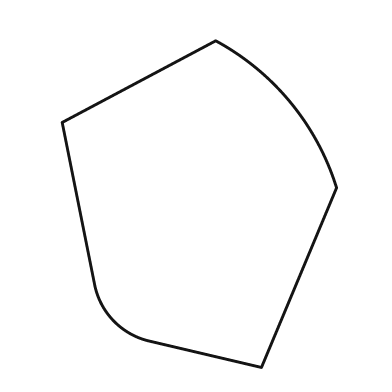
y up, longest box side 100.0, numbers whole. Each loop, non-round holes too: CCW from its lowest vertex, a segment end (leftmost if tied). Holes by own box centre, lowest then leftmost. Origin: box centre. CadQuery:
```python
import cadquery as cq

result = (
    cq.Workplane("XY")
    .moveTo(19.0, -50.0)
    .lineTo(42.0, 5.0)
    .threePointArc((28.0, 31.0), (5.0, 50.0))
    .lineTo(-42.0, 25.0)
    .lineTo(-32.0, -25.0)
    .threePointArc((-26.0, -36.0), (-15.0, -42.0))
    .close()
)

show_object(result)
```